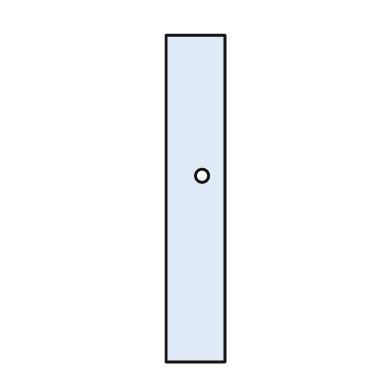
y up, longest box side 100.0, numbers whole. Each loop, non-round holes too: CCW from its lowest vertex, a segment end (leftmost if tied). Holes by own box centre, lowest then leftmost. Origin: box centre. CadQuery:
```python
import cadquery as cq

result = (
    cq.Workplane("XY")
    .moveTo(-9.0, -50.0)
    .lineTo(9.0, -50.0)
    .lineTo(9.0, 50.0)
    .lineTo(-9.0, 50.0)
    .close()
    .moveTo(2.0, 7.0)
    .circle(2.0)
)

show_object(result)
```